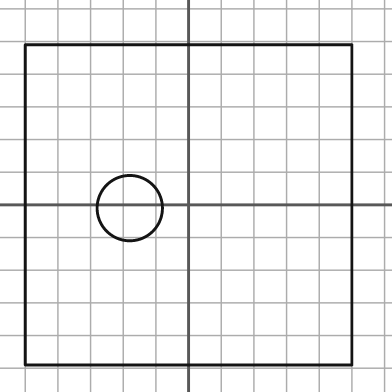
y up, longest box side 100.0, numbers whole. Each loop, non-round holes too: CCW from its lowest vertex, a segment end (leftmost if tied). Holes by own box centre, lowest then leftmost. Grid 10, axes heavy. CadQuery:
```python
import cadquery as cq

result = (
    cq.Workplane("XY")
    .moveTo(-50.0, -49.0)
    .lineTo(50.0, -49.0)
    .lineTo(50.0, 49.0)
    .lineTo(-50.0, 49.0)
    .close()
    .moveTo(-18.0, -1.0)
    .circle(10.0)
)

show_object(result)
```